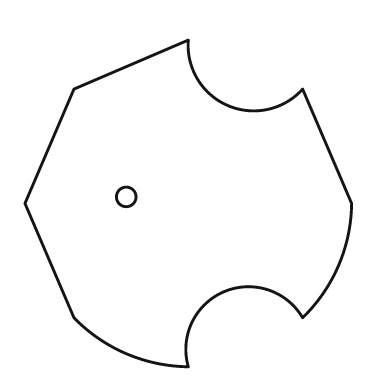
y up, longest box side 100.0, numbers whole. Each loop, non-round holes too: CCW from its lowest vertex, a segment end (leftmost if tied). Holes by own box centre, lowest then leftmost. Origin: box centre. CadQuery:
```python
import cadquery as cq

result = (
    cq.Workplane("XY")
    .moveTo(0.0, -50.0)
    .threePointArc((11.0, -27.0), (35.0, -35.0))
    .threePointArc((46.0, -19.0), (50.0, 0.0))
    .lineTo(35.0, 35.0)
    .threePointArc((12.0, 30.0), (0.0, 50.0))
    .lineTo(-35.0, 35.0)
    .lineTo(-50.0, 0.0)
    .lineTo(-35.0, -35.0)
    .threePointArc((-19.0, -46.0), (0.0, -50.0))
    .close()
    .moveTo(-19.0, 2.0)
    .circle(3.0)
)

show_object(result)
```